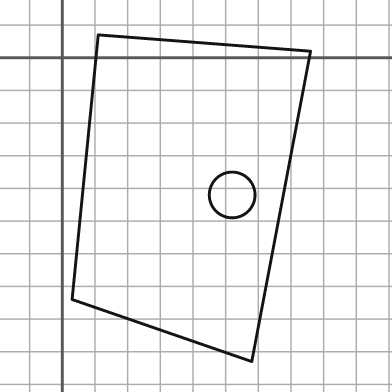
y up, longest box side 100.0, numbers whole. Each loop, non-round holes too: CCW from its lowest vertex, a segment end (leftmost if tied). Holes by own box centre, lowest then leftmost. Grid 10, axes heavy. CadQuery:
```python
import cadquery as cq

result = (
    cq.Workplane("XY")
    .moveTo(58.0, -93.0)
    .lineTo(76.0, 2.0)
    .lineTo(11.0, 7.0)
    .lineTo(3.0, -74.0)
    .close()
    .moveTo(52.0, -42.0)
    .circle(7.0)
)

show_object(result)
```